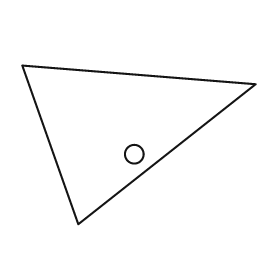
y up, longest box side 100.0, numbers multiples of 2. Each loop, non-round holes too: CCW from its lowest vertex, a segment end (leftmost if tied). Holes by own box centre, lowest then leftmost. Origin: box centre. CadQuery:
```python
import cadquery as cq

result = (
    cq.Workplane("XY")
    .moveTo(-26.0, -34.0)
    .lineTo(50.0, 26.0)
    .lineTo(-50.0, 34.0)
    .close()
    .moveTo(-2.0, -4.0)
    .circle(4.0)
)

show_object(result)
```